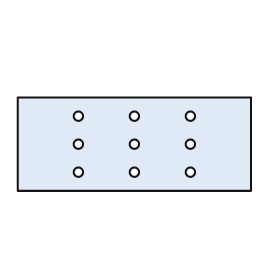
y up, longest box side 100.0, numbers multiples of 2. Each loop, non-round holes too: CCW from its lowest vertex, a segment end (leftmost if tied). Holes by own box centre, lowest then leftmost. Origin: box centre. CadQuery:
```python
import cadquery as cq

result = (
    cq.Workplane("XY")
    .moveTo(-50.0, -20.0)
    .lineTo(50.0, -20.0)
    .lineTo(50.0, 20.0)
    .lineTo(-50.0, 20.0)
    .close()
    .moveTo(-24.0, -12.0)
    .circle(2.0)
    .moveTo(0.0, -12.0)
    .circle(2.0)
    .moveTo(24.0, -12.0)
    .circle(2.0)
    .moveTo(-24.0, 0.0)
    .circle(2.0)
    .moveTo(0.0, 0.0)
    .circle(2.0)
    .moveTo(24.0, 0.0)
    .circle(2.0)
    .moveTo(-24.0, 12.0)
    .circle(2.0)
    .moveTo(0.0, 12.0)
    .circle(2.0)
    .moveTo(24.0, 12.0)
    .circle(2.0)
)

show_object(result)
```